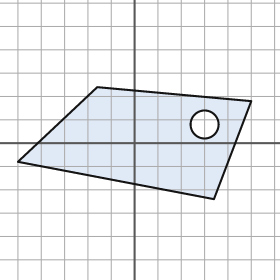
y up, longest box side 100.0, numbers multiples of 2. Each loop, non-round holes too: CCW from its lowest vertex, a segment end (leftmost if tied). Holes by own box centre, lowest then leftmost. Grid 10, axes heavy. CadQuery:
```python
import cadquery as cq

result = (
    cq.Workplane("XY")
    .moveTo(34.0, -24.0)
    .lineTo(50.0, 18.0)
    .lineTo(-16.0, 24.0)
    .lineTo(-50.0, -8.0)
    .close()
    .moveTo(30.0, 8.0)
    .circle(6.0)
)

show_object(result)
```